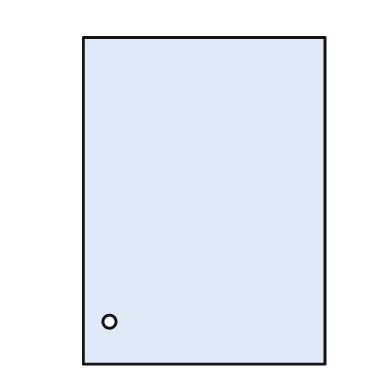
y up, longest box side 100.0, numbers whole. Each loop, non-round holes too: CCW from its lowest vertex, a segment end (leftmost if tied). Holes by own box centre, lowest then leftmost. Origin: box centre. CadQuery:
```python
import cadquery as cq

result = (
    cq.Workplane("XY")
    .moveTo(-37.0, -50.0)
    .lineTo(37.0, -50.0)
    .lineTo(37.0, 50.0)
    .lineTo(-37.0, 50.0)
    .close()
    .moveTo(-29.0, -37.0)
    .circle(2.0)
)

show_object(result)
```